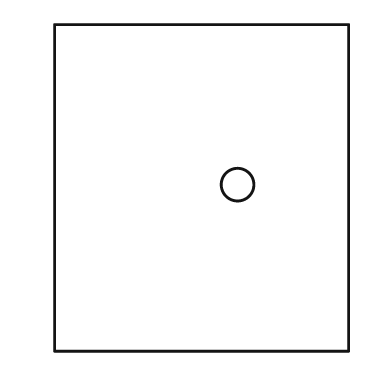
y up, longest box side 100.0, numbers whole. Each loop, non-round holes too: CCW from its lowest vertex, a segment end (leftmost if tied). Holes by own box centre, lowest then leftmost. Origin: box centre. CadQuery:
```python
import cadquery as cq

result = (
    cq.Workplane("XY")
    .moveTo(-45.0, -50.0)
    .lineTo(45.0, -50.0)
    .lineTo(45.0, 50.0)
    .lineTo(-45.0, 50.0)
    .close()
    .moveTo(11.0, 1.0)
    .circle(5.0)
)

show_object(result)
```